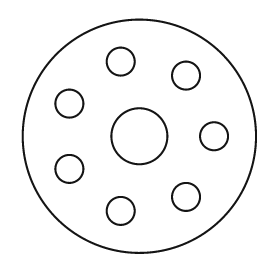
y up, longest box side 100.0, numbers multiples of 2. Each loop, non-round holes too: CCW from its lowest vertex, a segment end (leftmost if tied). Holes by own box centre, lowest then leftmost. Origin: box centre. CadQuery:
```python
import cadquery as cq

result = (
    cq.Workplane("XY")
    .moveTo(0.0, 0.0)
    .circle(50.0)
    .moveTo(-8.0, -32.0)
    .circle(6.0)
    .moveTo(20.0, -26.0)
    .circle(6.0)
    .moveTo(-30.0, -14.0)
    .circle(6.0)
    .moveTo(0.0, 0.0)
    .circle(12.0)
    .moveTo(32.0, 0.0)
    .circle(6.0)
    .moveTo(-30.0, 14.0)
    .circle(6.0)
    .moveTo(20.0, 26.0)
    .circle(6.0)
    .moveTo(-8.0, 32.0)
    .circle(6.0)
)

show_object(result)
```